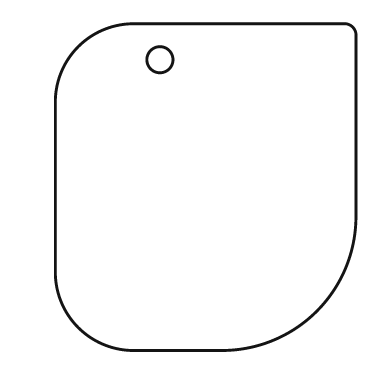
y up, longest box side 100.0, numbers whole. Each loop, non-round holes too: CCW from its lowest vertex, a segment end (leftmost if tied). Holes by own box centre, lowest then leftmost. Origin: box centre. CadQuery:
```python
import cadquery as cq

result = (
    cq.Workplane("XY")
    .moveTo(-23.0, -50.0)
    .lineTo(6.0, -50.0)
    .threePointArc((34.0, -38.0), (46.0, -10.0))
    .lineTo(46.0, 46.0)
    .threePointArc((45.0, 49.0), (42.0, 50.0))
    .lineTo(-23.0, 50.0)
    .threePointArc((-39.0, 43.0), (-46.0, 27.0))
    .lineTo(-46.0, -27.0)
    .threePointArc((-39.0, -43.0), (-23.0, -50.0))
    .close()
    .moveTo(-14.0, 39.0)
    .circle(4.0)
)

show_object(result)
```